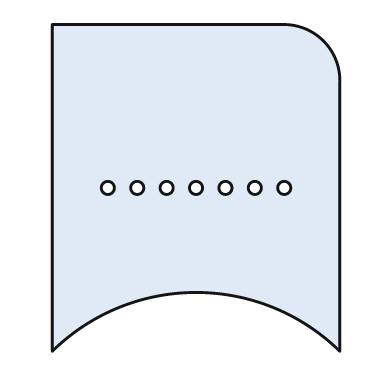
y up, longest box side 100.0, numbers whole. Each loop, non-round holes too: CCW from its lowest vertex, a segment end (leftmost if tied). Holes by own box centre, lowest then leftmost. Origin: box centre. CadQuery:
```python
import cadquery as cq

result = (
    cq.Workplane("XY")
    .moveTo(-44.0, -50.0)
    .threePointArc((0.0, -32.0), (44.0, -50.0))
    .lineTo(44.0, 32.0)
    .threePointArc((39.0, 45.0), (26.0, 50.0))
    .lineTo(-44.0, 50.0)
    .close()
    .moveTo(-27.0, 0.0)
    .circle(2.0)
    .moveTo(-18.0, 0.0)
    .circle(2.0)
    .moveTo(-9.0, 0.0)
    .circle(2.0)
    .moveTo(0.0, 0.0)
    .circle(2.0)
    .moveTo(9.0, 0.0)
    .circle(2.0)
    .moveTo(18.0, 0.0)
    .circle(2.0)
    .moveTo(27.0, 0.0)
    .circle(2.0)
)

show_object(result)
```